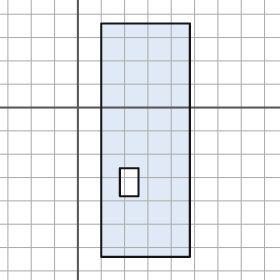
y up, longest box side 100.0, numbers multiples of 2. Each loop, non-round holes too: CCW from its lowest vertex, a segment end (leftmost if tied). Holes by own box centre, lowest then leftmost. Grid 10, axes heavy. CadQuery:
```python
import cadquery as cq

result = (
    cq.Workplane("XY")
    .moveTo(10.0, -64.0)
    .lineTo(48.0, -64.0)
    .lineTo(48.0, 36.0)
    .lineTo(10.0, 36.0)
    .close()
    .moveTo(18.0, -38.0)
    .lineTo(26.0, -38.0)
    .lineTo(26.0, -26.0)
    .lineTo(18.0, -26.0)
    .close()
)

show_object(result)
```